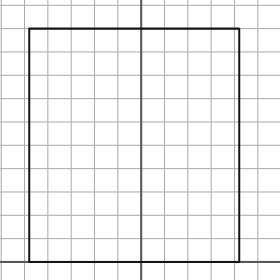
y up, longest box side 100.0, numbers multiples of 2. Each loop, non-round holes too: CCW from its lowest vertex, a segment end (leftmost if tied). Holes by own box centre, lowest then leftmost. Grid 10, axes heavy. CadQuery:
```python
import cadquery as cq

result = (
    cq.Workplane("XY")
    .moveTo(-48.0, 0.0)
    .lineTo(42.0, 0.0)
    .lineTo(42.0, 100.0)
    .lineTo(-48.0, 100.0)
    .close()
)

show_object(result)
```